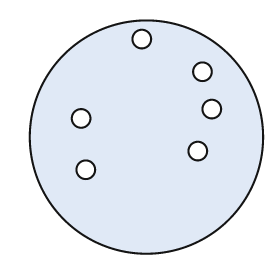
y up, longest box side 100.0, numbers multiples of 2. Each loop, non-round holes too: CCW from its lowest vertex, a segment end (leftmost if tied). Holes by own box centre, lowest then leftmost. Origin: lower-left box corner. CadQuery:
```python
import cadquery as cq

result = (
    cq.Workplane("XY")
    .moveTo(50.0, 50.0)
    .circle(50.0)
    .moveTo(24.0, 36.0)
    .circle(4.0)
    .moveTo(72.0, 44.0)
    .circle(4.0)
    .moveTo(22.0, 58.0)
    .circle(4.0)
    .moveTo(78.0, 62.0)
    .circle(4.0)
    .moveTo(74.0, 78.0)
    .circle(4.0)
    .moveTo(48.0, 92.0)
    .circle(4.0)
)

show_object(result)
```